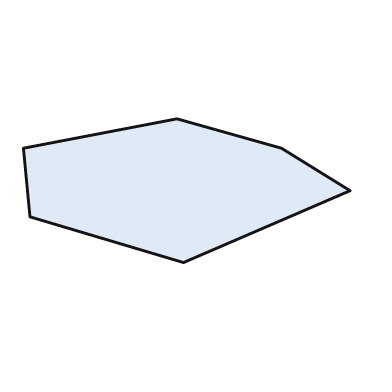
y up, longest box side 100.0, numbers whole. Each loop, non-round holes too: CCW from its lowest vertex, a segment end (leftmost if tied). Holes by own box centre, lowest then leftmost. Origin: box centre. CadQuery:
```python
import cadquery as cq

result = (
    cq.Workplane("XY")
    .moveTo(-1.0, -22.0)
    .lineTo(50.0, 0.0)
    .lineTo(29.0, 13.0)
    .lineTo(-3.0, 22.0)
    .lineTo(-50.0, 13.0)
    .lineTo(-48.0, -8.0)
    .close()
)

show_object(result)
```